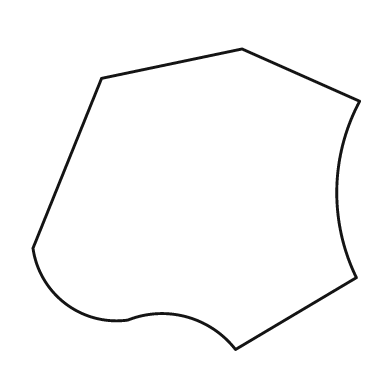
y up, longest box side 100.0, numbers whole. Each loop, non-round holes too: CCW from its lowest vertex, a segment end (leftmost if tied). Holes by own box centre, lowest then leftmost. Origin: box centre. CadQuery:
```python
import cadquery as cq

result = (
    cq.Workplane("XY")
    .moveTo(12.0, -46.0)
    .lineTo(49.0, -24.0)
    .threePointArc((43.0, 3.0), (50.0, 30.0))
    .lineTo(14.0, 46.0)
    .lineTo(-29.0, 37.0)
    .lineTo(-50.0, -15.0)
    .threePointArc((-40.0, -32.0), (-21.0, -37.0))
    .threePointArc((-3.0, -36.0), (12.0, -46.0))
    .close()
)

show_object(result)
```